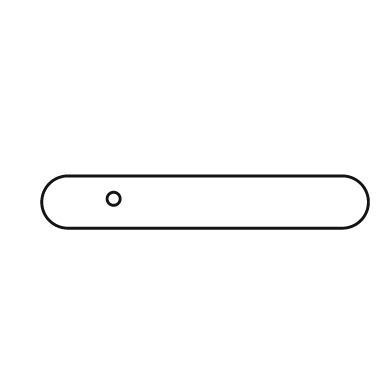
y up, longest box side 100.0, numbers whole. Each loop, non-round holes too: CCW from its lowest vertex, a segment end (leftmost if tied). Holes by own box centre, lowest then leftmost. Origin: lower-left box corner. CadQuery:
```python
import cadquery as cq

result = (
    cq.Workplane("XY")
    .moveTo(8.0, 0.0)
    .lineTo(92.0, 0.0)
    .threePointArc((100.0, 8.0), (92.0, 16.0))
    .lineTo(8.0, 16.0)
    .threePointArc((0.0, 8.0), (8.0, 0.0))
    .close()
    .moveTo(22.0, 9.0)
    .circle(2.0)
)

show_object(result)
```